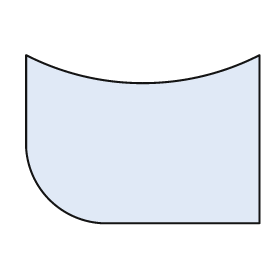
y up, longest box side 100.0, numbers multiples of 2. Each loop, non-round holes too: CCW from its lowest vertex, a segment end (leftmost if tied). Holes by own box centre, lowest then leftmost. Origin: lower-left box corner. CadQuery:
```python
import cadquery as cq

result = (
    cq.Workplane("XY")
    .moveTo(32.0, 0.0)
    .lineTo(100.0, 0.0)
    .lineTo(100.0, 72.0)
    .threePointArc((50.0, 60.0), (0.0, 72.0))
    .lineTo(0.0, 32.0)
    .threePointArc((10.0, 10.0), (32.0, 0.0))
    .close()
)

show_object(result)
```